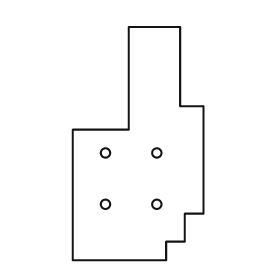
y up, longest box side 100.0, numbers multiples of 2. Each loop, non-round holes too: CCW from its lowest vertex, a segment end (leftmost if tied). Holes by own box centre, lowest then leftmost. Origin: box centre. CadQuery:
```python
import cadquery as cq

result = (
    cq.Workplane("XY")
    .moveTo(-28.0, -50.0)
    .lineTo(12.0, -50.0)
    .lineTo(12.0, -42.0)
    .lineTo(20.0, -42.0)
    .lineTo(20.0, -30.0)
    .lineTo(28.0, -30.0)
    .lineTo(28.0, 16.0)
    .lineTo(18.0, 16.0)
    .lineTo(18.0, 50.0)
    .lineTo(-4.0, 50.0)
    .lineTo(-4.0, 6.0)
    .lineTo(-28.0, 6.0)
    .close()
    .moveTo(-14.0, -26.0)
    .circle(2.0)
    .moveTo(8.0, -26.0)
    .circle(2.0)
    .moveTo(-14.0, -4.0)
    .circle(2.0)
    .moveTo(8.0, -4.0)
    .circle(2.0)
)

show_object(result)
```